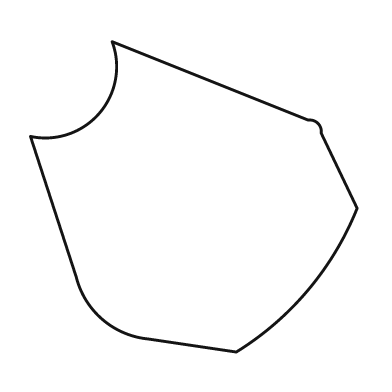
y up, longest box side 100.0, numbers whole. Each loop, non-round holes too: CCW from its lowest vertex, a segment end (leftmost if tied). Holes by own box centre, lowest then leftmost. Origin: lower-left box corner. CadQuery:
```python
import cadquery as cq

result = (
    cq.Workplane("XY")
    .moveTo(63.0, 0.0)
    .threePointArc((85.0, 19.0), (100.0, 44.0))
    .lineTo(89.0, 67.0)
    .threePointArc((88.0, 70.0), (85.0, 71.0))
    .lineTo(25.0, 95.0)
    .threePointArc((21.0, 73.0), (0.0, 66.0))
    .lineTo(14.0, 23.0)
    .threePointArc((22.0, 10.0), (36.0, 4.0))
    .close()
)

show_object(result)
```